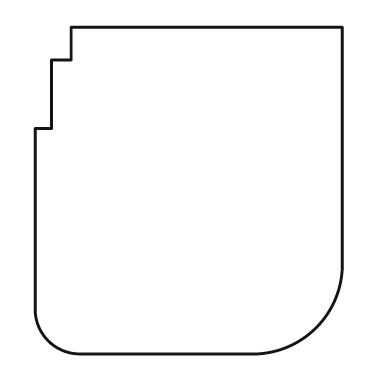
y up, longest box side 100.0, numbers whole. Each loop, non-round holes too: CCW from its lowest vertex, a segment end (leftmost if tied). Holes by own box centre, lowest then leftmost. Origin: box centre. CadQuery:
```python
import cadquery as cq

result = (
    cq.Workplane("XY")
    .moveTo(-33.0, -50.0)
    .lineTo(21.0, -50.0)
    .threePointArc((39.0, -42.0), (47.0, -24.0))
    .lineTo(47.0, 50.0)
    .lineTo(-36.0, 50.0)
    .lineTo(-36.0, 40.0)
    .lineTo(-42.0, 40.0)
    .lineTo(-42.0, 19.0)
    .lineTo(-47.0, 19.0)
    .lineTo(-47.0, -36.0)
    .threePointArc((-43.0, -46.0), (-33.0, -50.0))
    .close()
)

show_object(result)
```